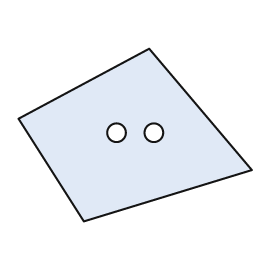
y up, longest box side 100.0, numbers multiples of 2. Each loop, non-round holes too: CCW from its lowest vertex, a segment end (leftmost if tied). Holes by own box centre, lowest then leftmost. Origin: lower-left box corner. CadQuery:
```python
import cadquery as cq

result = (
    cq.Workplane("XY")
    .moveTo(28.0, 0.0)
    .lineTo(100.0, 22.0)
    .lineTo(56.0, 74.0)
    .lineTo(0.0, 44.0)
    .close()
    .moveTo(42.0, 38.0)
    .circle(4.0)
    .moveTo(58.0, 38.0)
    .circle(4.0)
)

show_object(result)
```